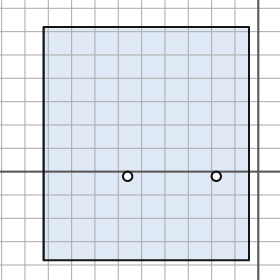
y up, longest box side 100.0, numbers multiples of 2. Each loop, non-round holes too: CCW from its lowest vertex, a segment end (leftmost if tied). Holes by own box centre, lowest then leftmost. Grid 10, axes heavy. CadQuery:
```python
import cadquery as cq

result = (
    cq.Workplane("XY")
    .moveTo(-92.0, -38.0)
    .lineTo(-4.0, -38.0)
    .lineTo(-4.0, 62.0)
    .lineTo(-92.0, 62.0)
    .close()
    .moveTo(-56.0, -2.0)
    .circle(2.0)
    .moveTo(-18.0, -2.0)
    .circle(2.0)
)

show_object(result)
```